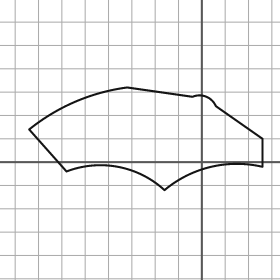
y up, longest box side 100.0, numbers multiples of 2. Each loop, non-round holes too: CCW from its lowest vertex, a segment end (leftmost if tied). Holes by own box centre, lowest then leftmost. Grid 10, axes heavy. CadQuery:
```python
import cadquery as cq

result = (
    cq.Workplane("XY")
    .moveTo(-16.0, -12.0)
    .threePointArc((4.0, -2.0), (26.0, -2.0))
    .lineTo(26.0, 10.0)
    .lineTo(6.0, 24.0)
    .threePointArc((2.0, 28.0), (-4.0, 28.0))
    .lineTo(-32.0, 32.0)
    .threePointArc((-54.0, 26.0), (-74.0, 14.0))
    .lineTo(-58.0, -4.0)
    .threePointArc((-36.0, -2.0), (-16.0, -12.0))
    .close()
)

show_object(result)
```